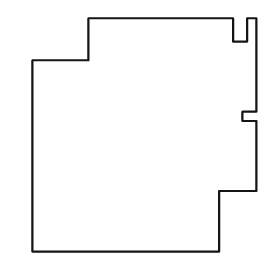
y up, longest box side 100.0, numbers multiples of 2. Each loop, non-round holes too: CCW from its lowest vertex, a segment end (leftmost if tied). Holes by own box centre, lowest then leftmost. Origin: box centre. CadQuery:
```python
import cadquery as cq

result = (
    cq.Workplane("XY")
    .moveTo(-48.0, -50.0)
    .lineTo(32.0, -50.0)
    .lineTo(32.0, -24.0)
    .lineTo(48.0, -24.0)
    .lineTo(48.0, 6.0)
    .lineTo(42.0, 6.0)
    .lineTo(42.0, 10.0)
    .lineTo(48.0, 10.0)
    .lineTo(48.0, 50.0)
    .lineTo(44.0, 50.0)
    .lineTo(44.0, 40.0)
    .lineTo(38.0, 40.0)
    .lineTo(38.0, 50.0)
    .lineTo(-24.0, 50.0)
    .lineTo(-24.0, 32.0)
    .lineTo(-48.0, 32.0)
    .close()
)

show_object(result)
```